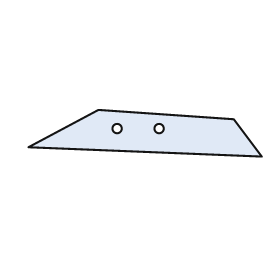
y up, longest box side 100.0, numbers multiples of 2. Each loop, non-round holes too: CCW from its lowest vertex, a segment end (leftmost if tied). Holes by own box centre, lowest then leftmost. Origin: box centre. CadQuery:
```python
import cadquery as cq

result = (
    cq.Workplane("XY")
    .moveTo(50.0, -10.0)
    .lineTo(38.0, 6.0)
    .lineTo(-20.0, 10.0)
    .lineTo(-50.0, -6.0)
    .close()
    .moveTo(-12.0, 2.0)
    .circle(2.0)
    .moveTo(6.0, 2.0)
    .circle(2.0)
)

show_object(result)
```